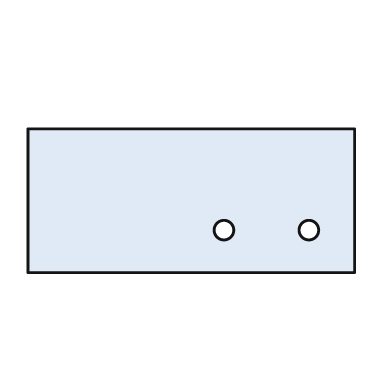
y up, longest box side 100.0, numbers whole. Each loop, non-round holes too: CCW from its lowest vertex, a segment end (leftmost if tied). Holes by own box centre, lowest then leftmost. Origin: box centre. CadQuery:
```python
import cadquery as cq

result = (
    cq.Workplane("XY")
    .moveTo(-50.0, -22.0)
    .lineTo(50.0, -22.0)
    .lineTo(50.0, 22.0)
    .lineTo(-50.0, 22.0)
    .close()
    .moveTo(10.0, -9.0)
    .circle(3.0)
    .moveTo(36.0, -9.0)
    .circle(3.0)
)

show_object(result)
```